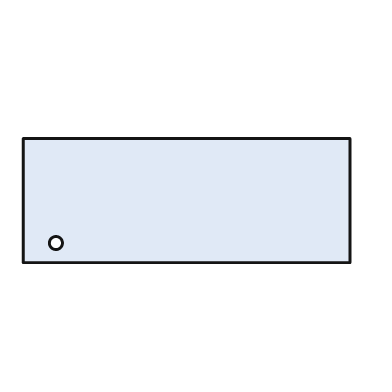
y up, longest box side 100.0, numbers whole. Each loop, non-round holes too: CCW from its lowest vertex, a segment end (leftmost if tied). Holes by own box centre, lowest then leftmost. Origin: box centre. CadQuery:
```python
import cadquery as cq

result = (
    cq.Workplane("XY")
    .moveTo(-50.0, -19.0)
    .lineTo(50.0, -19.0)
    .lineTo(50.0, 19.0)
    .lineTo(-50.0, 19.0)
    .close()
    .moveTo(-40.0, -13.0)
    .circle(2.0)
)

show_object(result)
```